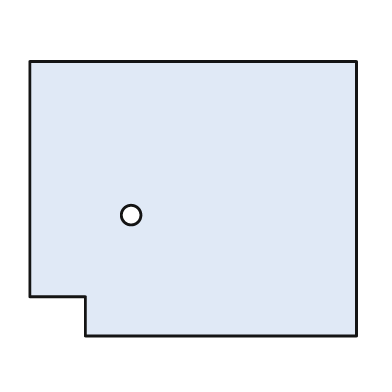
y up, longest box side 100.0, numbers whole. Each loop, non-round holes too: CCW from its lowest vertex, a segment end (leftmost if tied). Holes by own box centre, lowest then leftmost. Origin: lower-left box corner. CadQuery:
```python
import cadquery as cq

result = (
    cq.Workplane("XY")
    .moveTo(17.0, 0.0)
    .lineTo(100.0, 0.0)
    .lineTo(100.0, 84.0)
    .lineTo(0.0, 84.0)
    .lineTo(0.0, 12.0)
    .lineTo(17.0, 12.0)
    .close()
    .moveTo(31.0, 37.0)
    .circle(3.0)
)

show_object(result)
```